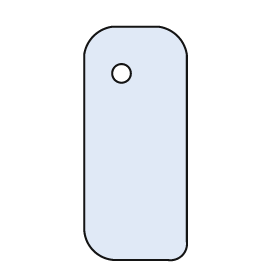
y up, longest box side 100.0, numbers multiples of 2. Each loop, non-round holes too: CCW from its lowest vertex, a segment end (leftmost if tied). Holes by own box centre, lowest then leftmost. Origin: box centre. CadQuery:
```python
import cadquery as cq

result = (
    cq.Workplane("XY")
    .moveTo(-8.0, -50.0)
    .lineTo(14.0, -50.0)
    .threePointArc((20.0, -48.0), (22.0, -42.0))
    .lineTo(22.0, 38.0)
    .threePointArc((18.0, 46.0), (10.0, 50.0))
    .lineTo(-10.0, 50.0)
    .threePointArc((-18.0, 46.0), (-22.0, 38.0))
    .lineTo(-22.0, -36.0)
    .threePointArc((-18.0, -46.0), (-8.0, -50.0))
    .close()
    .moveTo(-6.0, 30.0)
    .circle(4.0)
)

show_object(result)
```